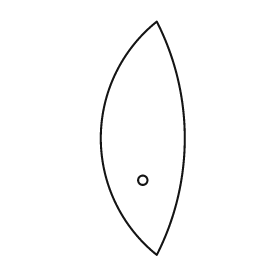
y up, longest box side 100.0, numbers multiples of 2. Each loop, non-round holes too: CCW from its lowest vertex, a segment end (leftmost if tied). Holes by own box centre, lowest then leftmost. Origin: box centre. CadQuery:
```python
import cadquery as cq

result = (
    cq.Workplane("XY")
    .moveTo(6.0, -50.0)
    .threePointArc((18.0, 0.0), (6.0, 50.0))
    .threePointArc((-18.0, 0.0), (6.0, -50.0))
    .close()
    .moveTo(0.0, -18.0)
    .circle(2.0)
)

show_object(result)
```